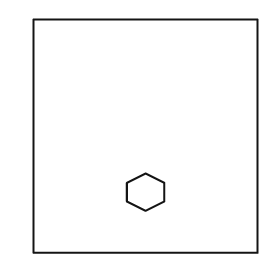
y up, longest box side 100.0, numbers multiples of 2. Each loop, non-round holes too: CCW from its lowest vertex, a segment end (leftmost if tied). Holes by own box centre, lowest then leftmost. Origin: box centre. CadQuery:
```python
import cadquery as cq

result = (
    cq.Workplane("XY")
    .moveTo(-48.0, -50.0)
    .lineTo(48.0, -50.0)
    .lineTo(48.0, 50.0)
    .lineTo(-48.0, 50.0)
    .close()
    .moveTo(0.0, -32.0)
    .lineTo(8.0, -28.0)
    .lineTo(8.0, -20.0)
    .lineTo(0.0, -16.0)
    .lineTo(-8.0, -20.0)
    .lineTo(-8.0, -28.0)
    .close()
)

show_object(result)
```